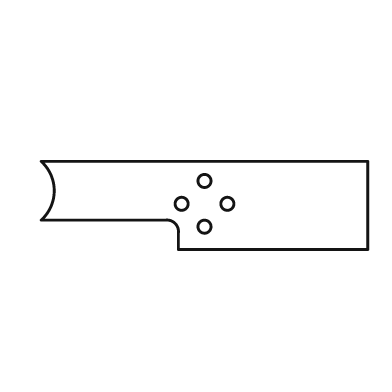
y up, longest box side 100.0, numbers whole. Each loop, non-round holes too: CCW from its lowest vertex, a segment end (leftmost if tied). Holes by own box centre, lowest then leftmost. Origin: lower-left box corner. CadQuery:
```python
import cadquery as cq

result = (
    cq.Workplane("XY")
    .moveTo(42.0, 0.0)
    .lineTo(100.0, 0.0)
    .lineTo(100.0, 27.0)
    .lineTo(0.0, 27.0)
    .threePointArc((4.0, 18.0), (0.0, 9.0))
    .lineTo(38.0, 9.0)
    .threePointArc((41.0, 8.0), (42.0, 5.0))
    .close()
    .moveTo(50.0, 7.0)
    .circle(2.0)
    .moveTo(43.0, 14.0)
    .circle(2.0)
    .moveTo(57.0, 14.0)
    .circle(2.0)
    .moveTo(50.0, 21.0)
    .circle(2.0)
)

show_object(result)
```